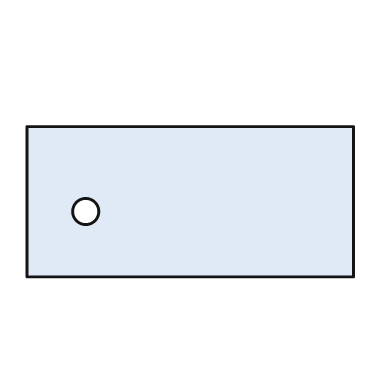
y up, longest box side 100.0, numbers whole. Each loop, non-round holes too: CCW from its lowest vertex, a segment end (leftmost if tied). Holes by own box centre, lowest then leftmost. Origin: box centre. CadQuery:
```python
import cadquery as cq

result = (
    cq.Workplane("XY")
    .moveTo(-50.0, -23.0)
    .lineTo(50.0, -23.0)
    .lineTo(50.0, 23.0)
    .lineTo(-50.0, 23.0)
    .close()
    .moveTo(-32.0, -3.0)
    .circle(4.0)
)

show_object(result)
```